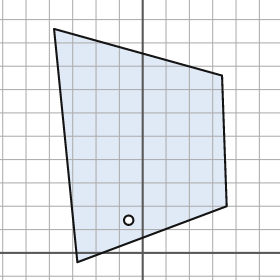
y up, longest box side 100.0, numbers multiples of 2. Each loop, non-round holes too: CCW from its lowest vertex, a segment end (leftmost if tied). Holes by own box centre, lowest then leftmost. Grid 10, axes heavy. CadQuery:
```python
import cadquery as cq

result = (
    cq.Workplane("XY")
    .moveTo(-28.0, -4.0)
    .lineTo(36.0, 20.0)
    .lineTo(34.0, 76.0)
    .lineTo(-38.0, 96.0)
    .close()
    .moveTo(-6.0, 14.0)
    .circle(2.0)
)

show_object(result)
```